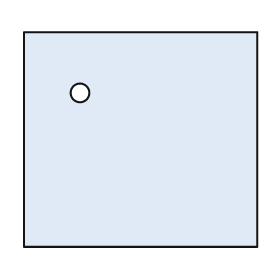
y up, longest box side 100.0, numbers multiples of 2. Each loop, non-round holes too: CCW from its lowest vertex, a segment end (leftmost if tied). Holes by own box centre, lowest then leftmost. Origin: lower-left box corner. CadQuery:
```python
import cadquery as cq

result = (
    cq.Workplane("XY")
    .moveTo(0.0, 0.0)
    .lineTo(100.0, 0.0)
    .lineTo(100.0, 92.0)
    .lineTo(0.0, 92.0)
    .close()
    .moveTo(24.0, 66.0)
    .circle(4.0)
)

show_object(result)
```